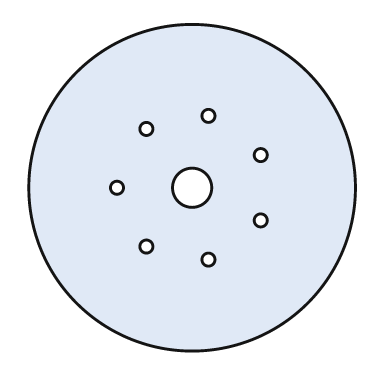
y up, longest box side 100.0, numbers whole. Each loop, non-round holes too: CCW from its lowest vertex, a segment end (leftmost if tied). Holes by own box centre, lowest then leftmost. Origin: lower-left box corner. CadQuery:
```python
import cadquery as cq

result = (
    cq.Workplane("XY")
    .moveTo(50.0, 50.0)
    .circle(50.0)
    .moveTo(55.0, 28.0)
    .circle(2.0)
    .moveTo(36.0, 32.0)
    .circle(2.0)
    .moveTo(71.0, 40.0)
    .circle(2.0)
    .moveTo(27.0, 50.0)
    .circle(2.0)
    .moveTo(50.0, 50.0)
    .circle(6.0)
    .moveTo(71.0, 60.0)
    .circle(2.0)
    .moveTo(36.0, 68.0)
    .circle(2.0)
    .moveTo(55.0, 72.0)
    .circle(2.0)
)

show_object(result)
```